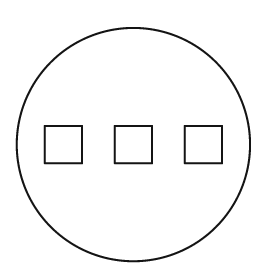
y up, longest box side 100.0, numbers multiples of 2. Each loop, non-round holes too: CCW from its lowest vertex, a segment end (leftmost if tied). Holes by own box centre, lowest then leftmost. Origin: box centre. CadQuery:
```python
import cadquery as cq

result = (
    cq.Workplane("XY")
    .moveTo(0.0, 0.0)
    .circle(50.0)
    .moveTo(-38.0, -8.0)
    .lineTo(-22.0, -8.0)
    .lineTo(-22.0, 8.0)
    .lineTo(-38.0, 8.0)
    .close()
    .moveTo(-8.0, -8.0)
    .lineTo(8.0, -8.0)
    .lineTo(8.0, 8.0)
    .lineTo(-8.0, 8.0)
    .close()
    .moveTo(22.0, -8.0)
    .lineTo(38.0, -8.0)
    .lineTo(38.0, 8.0)
    .lineTo(22.0, 8.0)
    .close()
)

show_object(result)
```